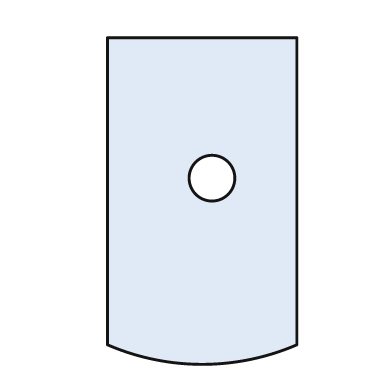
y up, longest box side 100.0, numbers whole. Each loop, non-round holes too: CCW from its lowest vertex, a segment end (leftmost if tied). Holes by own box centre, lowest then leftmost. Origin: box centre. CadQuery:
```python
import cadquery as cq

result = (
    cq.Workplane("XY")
    .moveTo(-29.0, -44.0)
    .threePointArc((0.0, -50.0), (29.0, -44.0))
    .lineTo(29.0, 50.0)
    .lineTo(-29.0, 50.0)
    .close()
    .moveTo(3.0, 7.0)
    .circle(7.0)
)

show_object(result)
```